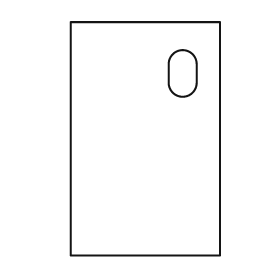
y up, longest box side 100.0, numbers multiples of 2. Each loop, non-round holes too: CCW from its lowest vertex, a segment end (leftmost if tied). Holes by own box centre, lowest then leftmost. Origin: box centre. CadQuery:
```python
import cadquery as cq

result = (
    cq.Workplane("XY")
    .moveTo(-32.0, -50.0)
    .lineTo(32.0, -50.0)
    .lineTo(32.0, 50.0)
    .lineTo(-32.0, 50.0)
    .close()
    .moveTo(10.0, 24.0)
    .threePointArc((16.0, 18.0), (22.0, 24.0))
    .lineTo(22.0, 32.0)
    .threePointArc((16.0, 38.0), (10.0, 32.0))
    .close()
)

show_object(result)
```